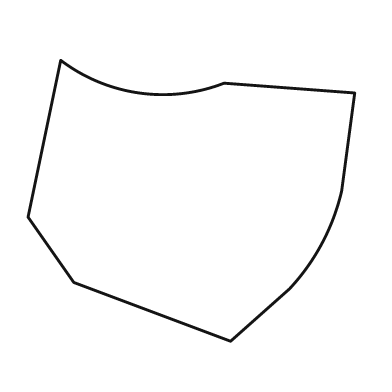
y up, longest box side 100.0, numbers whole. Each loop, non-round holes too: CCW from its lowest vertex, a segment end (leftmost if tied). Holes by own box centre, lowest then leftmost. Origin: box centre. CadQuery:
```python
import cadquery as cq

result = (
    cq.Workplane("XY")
    .moveTo(12.0, -43.0)
    .lineTo(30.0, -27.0)
    .threePointArc((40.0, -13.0), (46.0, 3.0))
    .lineTo(50.0, 33.0)
    .lineTo(10.0, 36.0)
    .threePointArc((-16.0, 33.0), (-40.0, 43.0))
    .lineTo(-50.0, -5.0)
    .lineTo(-36.0, -25.0)
    .close()
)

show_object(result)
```